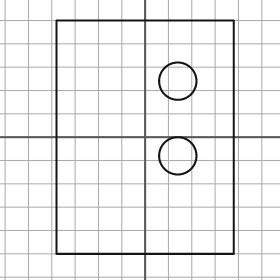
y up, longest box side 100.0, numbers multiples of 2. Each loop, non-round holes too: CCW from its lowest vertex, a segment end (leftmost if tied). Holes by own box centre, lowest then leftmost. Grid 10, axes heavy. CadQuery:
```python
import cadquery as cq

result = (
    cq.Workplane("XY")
    .moveTo(-38.0, -50.0)
    .lineTo(38.0, -50.0)
    .lineTo(38.0, 50.0)
    .lineTo(-38.0, 50.0)
    .close()
    .moveTo(14.0, -8.0)
    .circle(8.0)
    .moveTo(14.0, 24.0)
    .circle(8.0)
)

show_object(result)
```